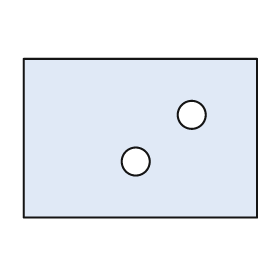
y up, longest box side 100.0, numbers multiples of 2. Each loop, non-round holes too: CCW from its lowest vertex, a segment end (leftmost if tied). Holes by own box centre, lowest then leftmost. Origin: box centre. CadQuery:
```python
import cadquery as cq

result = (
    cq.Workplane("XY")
    .moveTo(-50.0, -34.0)
    .lineTo(50.0, -34.0)
    .lineTo(50.0, 34.0)
    .lineTo(-50.0, 34.0)
    .close()
    .moveTo(-2.0, -10.0)
    .circle(6.0)
    .moveTo(22.0, 10.0)
    .circle(6.0)
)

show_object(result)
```